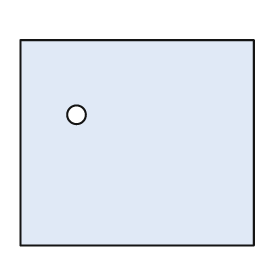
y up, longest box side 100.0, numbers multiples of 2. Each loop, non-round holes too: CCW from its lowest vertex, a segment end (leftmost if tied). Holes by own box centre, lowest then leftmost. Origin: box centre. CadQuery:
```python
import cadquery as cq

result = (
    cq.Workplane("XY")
    .moveTo(-50.0, -44.0)
    .lineTo(50.0, -44.0)
    .lineTo(50.0, 44.0)
    .lineTo(-50.0, 44.0)
    .close()
    .moveTo(-26.0, 12.0)
    .circle(4.0)
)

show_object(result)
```